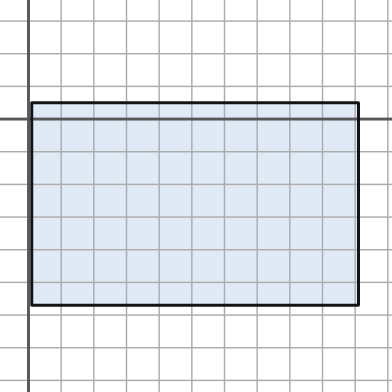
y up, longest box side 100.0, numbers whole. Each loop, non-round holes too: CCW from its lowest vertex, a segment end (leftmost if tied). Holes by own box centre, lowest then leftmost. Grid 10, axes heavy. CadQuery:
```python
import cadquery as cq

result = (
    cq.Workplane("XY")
    .moveTo(1.0, -57.0)
    .lineTo(101.0, -57.0)
    .lineTo(101.0, 5.0)
    .lineTo(1.0, 5.0)
    .close()
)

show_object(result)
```